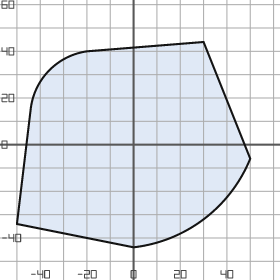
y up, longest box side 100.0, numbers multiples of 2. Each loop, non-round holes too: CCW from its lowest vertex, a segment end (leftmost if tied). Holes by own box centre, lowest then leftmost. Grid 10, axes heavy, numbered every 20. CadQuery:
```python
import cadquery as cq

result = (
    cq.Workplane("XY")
    .moveTo(0.0, -44.0)
    .threePointArc((30.0, -32.0), (50.0, -6.0))
    .lineTo(30.0, 44.0)
    .lineTo(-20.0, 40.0)
    .threePointArc((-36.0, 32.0), (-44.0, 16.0))
    .lineTo(-50.0, -34.0)
    .close()
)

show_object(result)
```